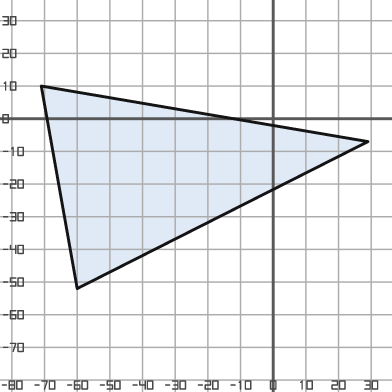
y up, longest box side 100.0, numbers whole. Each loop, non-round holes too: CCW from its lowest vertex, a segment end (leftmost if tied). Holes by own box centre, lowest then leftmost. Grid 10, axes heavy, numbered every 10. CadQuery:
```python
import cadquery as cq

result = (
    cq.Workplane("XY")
    .moveTo(-60.0, -52.0)
    .lineTo(29.0, -7.0)
    .lineTo(-71.0, 10.0)
    .close()
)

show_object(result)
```